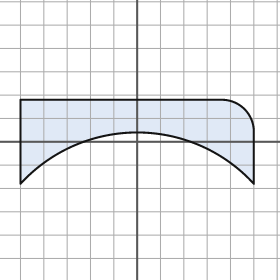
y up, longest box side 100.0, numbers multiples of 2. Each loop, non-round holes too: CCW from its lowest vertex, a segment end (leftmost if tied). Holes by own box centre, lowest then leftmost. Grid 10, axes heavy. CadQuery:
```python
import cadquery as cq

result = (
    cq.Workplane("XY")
    .moveTo(-50.0, -18.0)
    .threePointArc((0.0, 4.0), (50.0, -18.0))
    .lineTo(50.0, 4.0)
    .threePointArc((46.0, 14.0), (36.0, 18.0))
    .lineTo(-50.0, 18.0)
    .close()
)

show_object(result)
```